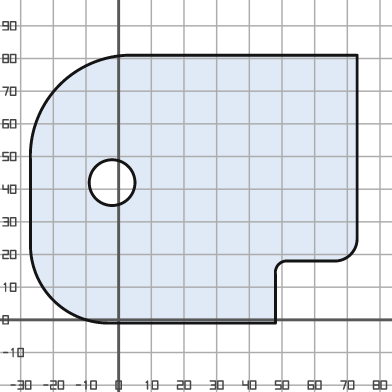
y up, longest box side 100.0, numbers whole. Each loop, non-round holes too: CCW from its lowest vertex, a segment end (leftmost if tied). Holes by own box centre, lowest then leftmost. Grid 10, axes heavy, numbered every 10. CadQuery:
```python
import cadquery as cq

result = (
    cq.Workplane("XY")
    .moveTo(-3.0, -1.0)
    .lineTo(48.0, -1.0)
    .lineTo(48.0, 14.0)
    .threePointArc((49.0, 17.0), (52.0, 18.0))
    .lineTo(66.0, 18.0)
    .threePointArc((71.0, 20.0), (73.0, 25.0))
    .lineTo(73.0, 81.0)
    .lineTo(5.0, 81.0)
    .threePointArc((-18.0, 72.0), (-27.0, 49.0))
    .lineTo(-27.0, 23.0)
    .threePointArc((-20.0, 6.0), (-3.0, -1.0))
    .close()
    .moveTo(-2.0, 42.0)
    .circle(7.0)
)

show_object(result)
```